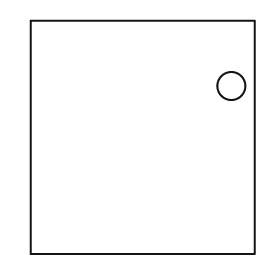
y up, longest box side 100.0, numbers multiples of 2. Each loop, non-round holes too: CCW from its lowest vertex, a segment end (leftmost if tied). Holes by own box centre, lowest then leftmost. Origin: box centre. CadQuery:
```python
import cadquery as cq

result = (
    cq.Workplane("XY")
    .moveTo(-48.0, -50.0)
    .lineTo(48.0, -50.0)
    .lineTo(48.0, 50.0)
    .lineTo(-48.0, 50.0)
    .close()
    .moveTo(38.0, 22.0)
    .circle(6.0)
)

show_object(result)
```